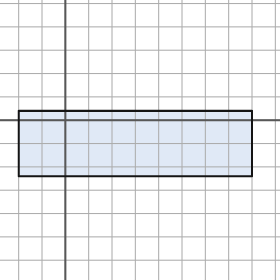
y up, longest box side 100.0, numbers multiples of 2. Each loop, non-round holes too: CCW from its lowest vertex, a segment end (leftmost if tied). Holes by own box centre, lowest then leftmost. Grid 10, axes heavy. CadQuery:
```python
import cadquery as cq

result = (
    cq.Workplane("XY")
    .moveTo(-20.0, -24.0)
    .lineTo(80.0, -24.0)
    .lineTo(80.0, 4.0)
    .lineTo(-20.0, 4.0)
    .close()
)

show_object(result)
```